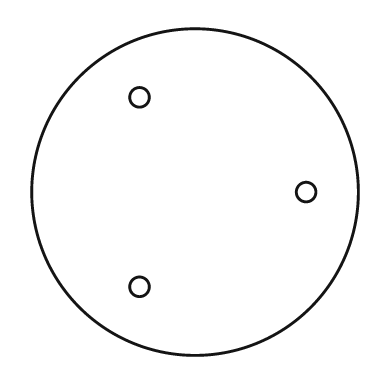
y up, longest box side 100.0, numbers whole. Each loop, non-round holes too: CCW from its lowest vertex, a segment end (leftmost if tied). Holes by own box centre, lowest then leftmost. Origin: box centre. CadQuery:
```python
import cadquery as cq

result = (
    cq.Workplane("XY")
    .moveTo(0.0, 0.0)
    .circle(50.0)
    .moveTo(-17.0, -29.0)
    .circle(3.0)
    .moveTo(34.0, 0.0)
    .circle(3.0)
    .moveTo(-17.0, 29.0)
    .circle(3.0)
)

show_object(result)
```